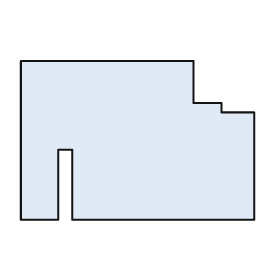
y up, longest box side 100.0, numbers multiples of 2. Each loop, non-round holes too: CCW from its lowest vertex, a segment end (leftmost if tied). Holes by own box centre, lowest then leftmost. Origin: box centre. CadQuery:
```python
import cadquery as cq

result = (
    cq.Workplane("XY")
    .moveTo(-50.0, -34.0)
    .lineTo(-34.0, -34.0)
    .lineTo(-34.0, -4.0)
    .lineTo(-28.0, -4.0)
    .lineTo(-28.0, -34.0)
    .lineTo(50.0, -34.0)
    .lineTo(50.0, 12.0)
    .lineTo(36.0, 12.0)
    .lineTo(36.0, 16.0)
    .lineTo(24.0, 16.0)
    .lineTo(24.0, 34.0)
    .lineTo(-50.0, 34.0)
    .close()
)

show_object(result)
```